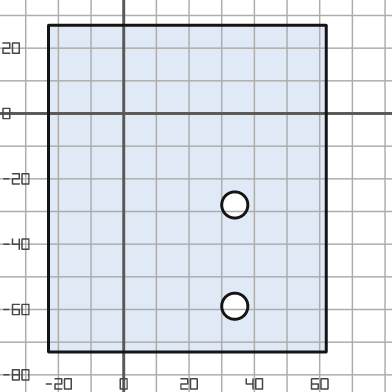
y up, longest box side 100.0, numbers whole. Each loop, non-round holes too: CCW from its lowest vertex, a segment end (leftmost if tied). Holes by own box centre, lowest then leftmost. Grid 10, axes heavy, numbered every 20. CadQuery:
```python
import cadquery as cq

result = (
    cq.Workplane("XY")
    .moveTo(-23.0, -73.0)
    .lineTo(62.0, -73.0)
    .lineTo(62.0, 27.0)
    .lineTo(-23.0, 27.0)
    .close()
    .moveTo(34.0, -59.0)
    .circle(4.0)
    .moveTo(34.0, -28.0)
    .circle(4.0)
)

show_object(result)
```